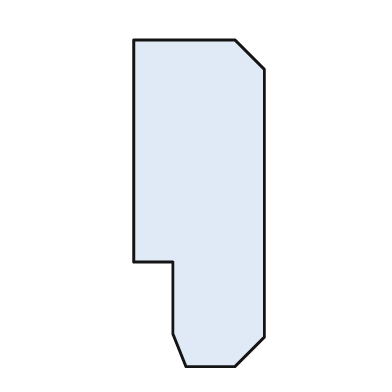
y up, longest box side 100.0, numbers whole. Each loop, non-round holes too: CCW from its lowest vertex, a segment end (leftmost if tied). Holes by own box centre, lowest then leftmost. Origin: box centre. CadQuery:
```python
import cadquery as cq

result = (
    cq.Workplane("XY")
    .moveTo(-4.0, -50.0)
    .lineTo(11.0, -50.0)
    .lineTo(20.0, -41.0)
    .lineTo(20.0, 41.0)
    .lineTo(11.0, 50.0)
    .lineTo(-20.0, 50.0)
    .lineTo(-20.0, -18.0)
    .lineTo(-8.0, -18.0)
    .lineTo(-8.0, -40.0)
    .close()
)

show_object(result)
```